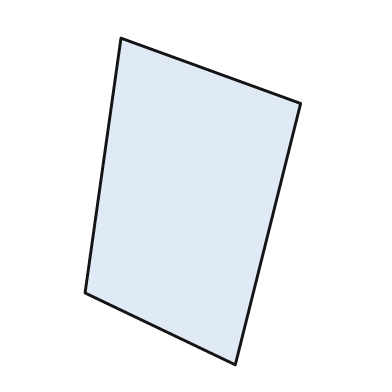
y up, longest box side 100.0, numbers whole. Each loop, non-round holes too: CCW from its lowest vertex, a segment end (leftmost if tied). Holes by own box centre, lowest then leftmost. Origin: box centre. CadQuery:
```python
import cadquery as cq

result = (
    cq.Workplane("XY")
    .moveTo(13.0, -50.0)
    .lineTo(33.0, 30.0)
    .lineTo(-22.0, 50.0)
    .lineTo(-33.0, -28.0)
    .close()
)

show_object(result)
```